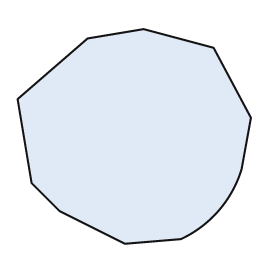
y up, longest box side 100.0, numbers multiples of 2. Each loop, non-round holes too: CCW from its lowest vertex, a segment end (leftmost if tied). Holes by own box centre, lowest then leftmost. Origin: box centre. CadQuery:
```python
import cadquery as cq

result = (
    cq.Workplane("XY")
    .moveTo(-4.0, -46.0)
    .lineTo(20.0, -44.0)
    .threePointArc((36.0, -32.0), (46.0, -14.0))
    .lineTo(50.0, 8.0)
    .lineTo(34.0, 38.0)
    .lineTo(4.0, 46.0)
    .lineTo(-20.0, 42.0)
    .lineTo(-50.0, 16.0)
    .lineTo(-44.0, -20.0)
    .lineTo(-32.0, -32.0)
    .close()
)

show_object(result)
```